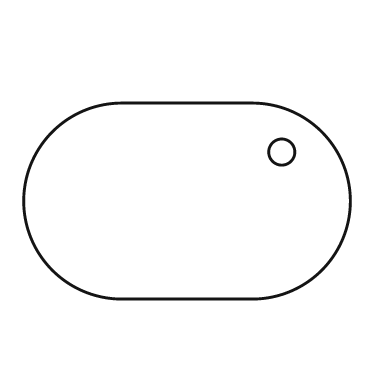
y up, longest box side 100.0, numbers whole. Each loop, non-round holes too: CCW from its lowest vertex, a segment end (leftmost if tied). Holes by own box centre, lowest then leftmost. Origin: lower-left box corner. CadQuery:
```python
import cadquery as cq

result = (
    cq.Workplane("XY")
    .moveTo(30.0, 0.0)
    .lineTo(70.0, 0.0)
    .threePointArc((100.0, 30.0), (70.0, 60.0))
    .lineTo(30.0, 60.0)
    .threePointArc((0.0, 30.0), (30.0, 0.0))
    .close()
    .moveTo(79.0, 45.0)
    .circle(4.0)
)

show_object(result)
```